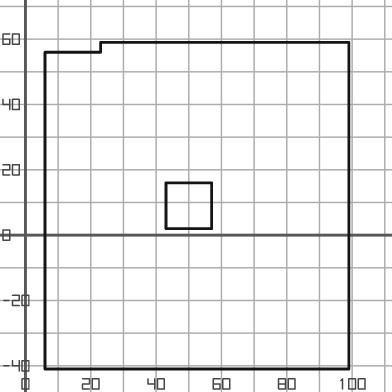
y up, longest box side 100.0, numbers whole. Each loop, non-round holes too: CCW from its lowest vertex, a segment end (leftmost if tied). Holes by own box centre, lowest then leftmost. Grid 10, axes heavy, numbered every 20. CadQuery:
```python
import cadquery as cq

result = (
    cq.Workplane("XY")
    .moveTo(6.0, -41.0)
    .lineTo(99.0, -41.0)
    .lineTo(99.0, 59.0)
    .lineTo(23.0, 59.0)
    .lineTo(23.0, 56.0)
    .lineTo(6.0, 56.0)
    .close()
    .moveTo(43.0, 2.0)
    .lineTo(57.0, 2.0)
    .lineTo(57.0, 16.0)
    .lineTo(43.0, 16.0)
    .close()
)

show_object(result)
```